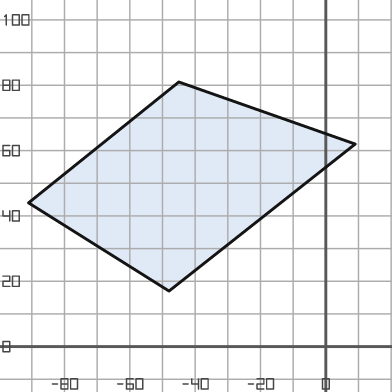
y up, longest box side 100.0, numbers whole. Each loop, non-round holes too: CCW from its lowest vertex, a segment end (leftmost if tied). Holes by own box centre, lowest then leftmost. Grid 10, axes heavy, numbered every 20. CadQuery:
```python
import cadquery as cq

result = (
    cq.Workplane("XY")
    .moveTo(-48.0, 17.0)
    .lineTo(9.0, 62.0)
    .lineTo(-45.0, 81.0)
    .lineTo(-91.0, 44.0)
    .close()
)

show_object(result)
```